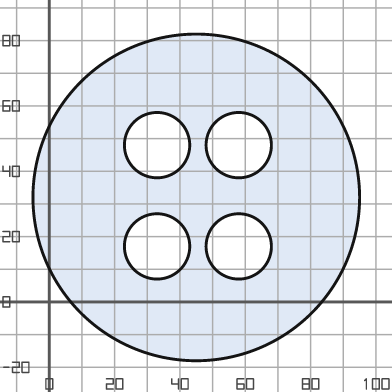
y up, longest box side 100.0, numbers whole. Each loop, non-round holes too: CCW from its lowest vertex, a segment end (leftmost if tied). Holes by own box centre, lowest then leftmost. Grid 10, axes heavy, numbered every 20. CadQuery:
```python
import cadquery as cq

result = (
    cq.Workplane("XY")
    .moveTo(45.0, 32.0)
    .circle(50.0)
    .moveTo(33.0, 17.0)
    .circle(10.0)
    .moveTo(58.0, 17.0)
    .circle(10.0)
    .moveTo(33.0, 48.0)
    .circle(10.0)
    .moveTo(58.0, 48.0)
    .circle(10.0)
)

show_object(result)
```